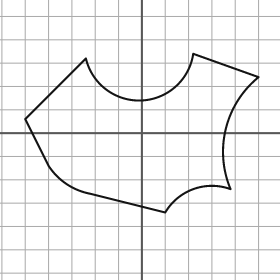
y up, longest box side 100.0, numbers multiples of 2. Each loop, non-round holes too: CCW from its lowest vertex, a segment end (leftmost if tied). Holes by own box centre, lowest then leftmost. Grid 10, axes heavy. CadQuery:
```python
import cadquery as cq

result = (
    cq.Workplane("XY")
    .moveTo(10.0, -34.0)
    .threePointArc((22.0, -24.0), (38.0, -24.0))
    .threePointArc((36.0, 2.0), (50.0, 24.0))
    .lineTo(22.0, 34.0)
    .threePointArc((0.0, 14.0), (-24.0, 32.0))
    .lineTo(-50.0, 6.0)
    .lineTo(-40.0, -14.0)
    .threePointArc((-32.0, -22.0), (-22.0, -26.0))
    .close()
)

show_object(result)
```